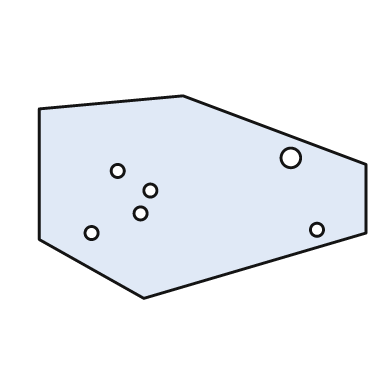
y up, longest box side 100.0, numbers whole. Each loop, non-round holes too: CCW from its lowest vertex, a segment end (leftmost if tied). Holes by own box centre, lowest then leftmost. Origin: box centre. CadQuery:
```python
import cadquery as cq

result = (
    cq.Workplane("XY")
    .moveTo(-18.0, -31.0)
    .lineTo(50.0, -11.0)
    .lineTo(50.0, 10.0)
    .lineTo(-6.0, 31.0)
    .lineTo(-50.0, 27.0)
    .lineTo(-50.0, -13.0)
    .close()
    .moveTo(-34.0, -11.0)
    .circle(2.0)
    .moveTo(35.0, -10.0)
    .circle(2.0)
    .moveTo(-19.0, -5.0)
    .circle(2.0)
    .moveTo(-16.0, 2.0)
    .circle(2.0)
    .moveTo(-26.0, 8.0)
    .circle(2.0)
    .moveTo(27.0, 12.0)
    .circle(3.0)
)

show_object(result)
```